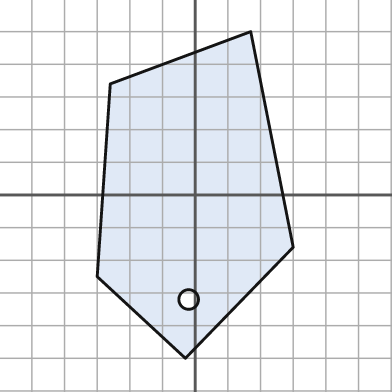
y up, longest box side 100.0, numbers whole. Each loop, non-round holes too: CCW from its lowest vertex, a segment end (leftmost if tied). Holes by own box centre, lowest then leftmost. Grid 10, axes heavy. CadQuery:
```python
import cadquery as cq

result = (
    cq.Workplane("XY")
    .moveTo(-3.0, -50.0)
    .lineTo(30.0, -16.0)
    .lineTo(17.0, 50.0)
    .lineTo(-26.0, 34.0)
    .lineTo(-30.0, -25.0)
    .close()
    .moveTo(-2.0, -32.0)
    .circle(3.0)
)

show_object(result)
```